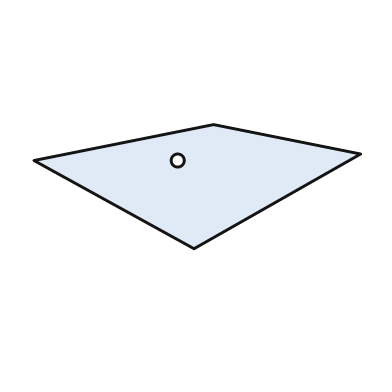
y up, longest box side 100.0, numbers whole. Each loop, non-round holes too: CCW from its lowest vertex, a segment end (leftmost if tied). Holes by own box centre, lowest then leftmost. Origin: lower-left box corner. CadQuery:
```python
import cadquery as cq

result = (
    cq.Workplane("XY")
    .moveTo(49.0, 0.0)
    .lineTo(100.0, 29.0)
    .lineTo(55.0, 38.0)
    .lineTo(0.0, 27.0)
    .close()
    .moveTo(44.0, 27.0)
    .circle(2.0)
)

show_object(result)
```